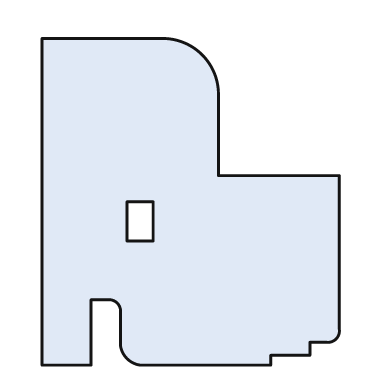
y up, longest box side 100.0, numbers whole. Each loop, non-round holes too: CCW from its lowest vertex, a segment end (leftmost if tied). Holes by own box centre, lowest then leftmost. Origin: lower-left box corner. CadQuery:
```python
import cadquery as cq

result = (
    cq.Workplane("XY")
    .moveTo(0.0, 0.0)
    .lineTo(15.0, 0.0)
    .lineTo(15.0, 20.0)
    .lineTo(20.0, 20.0)
    .threePointArc((23.0, 19.0), (24.0, 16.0))
    .lineTo(24.0, 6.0)
    .threePointArc((26.0, 2.0), (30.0, 0.0))
    .lineTo(70.0, 0.0)
    .lineTo(70.0, 3.0)
    .lineTo(82.0, 3.0)
    .lineTo(82.0, 7.0)
    .lineTo(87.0, 7.0)
    .threePointArc((90.0, 8.0), (91.0, 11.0))
    .lineTo(91.0, 58.0)
    .lineTo(54.0, 58.0)
    .lineTo(54.0, 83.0)
    .threePointArc((49.0, 95.0), (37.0, 100.0))
    .lineTo(0.0, 100.0)
    .close()
    .moveTo(26.0, 38.0)
    .lineTo(34.0, 38.0)
    .lineTo(34.0, 50.0)
    .lineTo(26.0, 50.0)
    .close()
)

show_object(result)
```